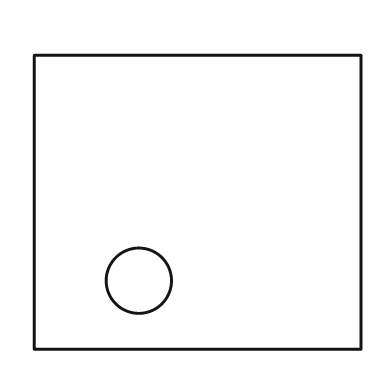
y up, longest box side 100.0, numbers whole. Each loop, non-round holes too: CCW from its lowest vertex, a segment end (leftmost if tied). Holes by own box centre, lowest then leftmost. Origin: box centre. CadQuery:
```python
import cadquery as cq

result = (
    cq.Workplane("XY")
    .moveTo(-50.0, -45.0)
    .lineTo(50.0, -45.0)
    .lineTo(50.0, 45.0)
    .lineTo(-50.0, 45.0)
    .close()
    .moveTo(-18.0, -24.0)
    .circle(10.0)
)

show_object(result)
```